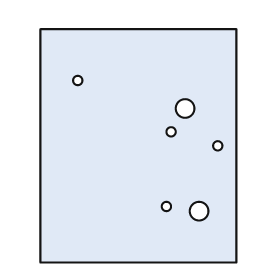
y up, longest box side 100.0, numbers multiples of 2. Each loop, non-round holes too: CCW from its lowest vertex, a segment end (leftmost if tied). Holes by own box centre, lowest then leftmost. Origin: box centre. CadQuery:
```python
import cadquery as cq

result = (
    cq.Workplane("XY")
    .moveTo(-42.0, -50.0)
    .lineTo(42.0, -50.0)
    .lineTo(42.0, 50.0)
    .lineTo(-42.0, 50.0)
    .close()
    .moveTo(26.0, -28.0)
    .circle(4.0)
    .moveTo(12.0, -26.0)
    .circle(2.0)
    .moveTo(34.0, 0.0)
    .circle(2.0)
    .moveTo(14.0, 6.0)
    .circle(2.0)
    .moveTo(20.0, 16.0)
    .circle(4.0)
    .moveTo(-26.0, 28.0)
    .circle(2.0)
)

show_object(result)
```